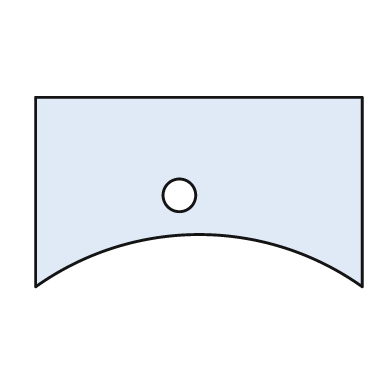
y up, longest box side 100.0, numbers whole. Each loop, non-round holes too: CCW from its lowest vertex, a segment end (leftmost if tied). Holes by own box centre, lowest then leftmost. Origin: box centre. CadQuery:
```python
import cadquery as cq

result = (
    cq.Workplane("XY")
    .moveTo(-50.0, -29.0)
    .threePointArc((0.0, -13.0), (50.0, -29.0))
    .lineTo(50.0, 29.0)
    .lineTo(-50.0, 29.0)
    .close()
    .moveTo(-6.0, -1.0)
    .circle(5.0)
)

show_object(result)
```